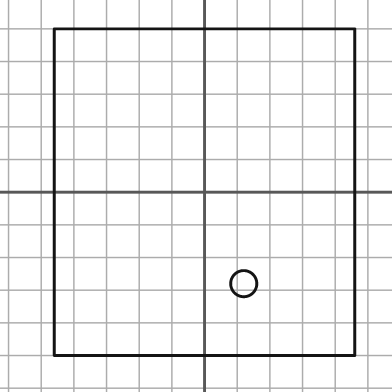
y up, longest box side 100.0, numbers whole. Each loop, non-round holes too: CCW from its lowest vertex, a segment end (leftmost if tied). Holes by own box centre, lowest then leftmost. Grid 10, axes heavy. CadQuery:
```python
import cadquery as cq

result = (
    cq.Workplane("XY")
    .moveTo(-46.0, -50.0)
    .lineTo(46.0, -50.0)
    .lineTo(46.0, 50.0)
    .lineTo(-46.0, 50.0)
    .close()
    .moveTo(12.0, -28.0)
    .circle(4.0)
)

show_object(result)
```